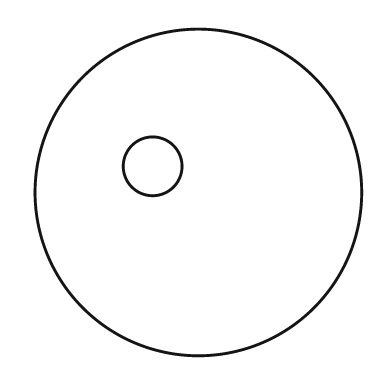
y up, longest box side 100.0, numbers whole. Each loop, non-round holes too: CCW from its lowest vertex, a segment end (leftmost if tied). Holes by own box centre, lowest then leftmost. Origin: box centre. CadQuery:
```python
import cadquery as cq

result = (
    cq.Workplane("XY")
    .moveTo(0.0, 0.0)
    .circle(50.0)
    .moveTo(-14.0, 8.0)
    .circle(9.0)
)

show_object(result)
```